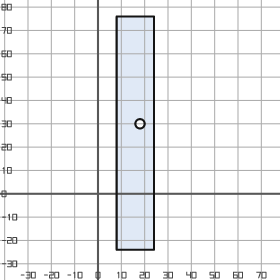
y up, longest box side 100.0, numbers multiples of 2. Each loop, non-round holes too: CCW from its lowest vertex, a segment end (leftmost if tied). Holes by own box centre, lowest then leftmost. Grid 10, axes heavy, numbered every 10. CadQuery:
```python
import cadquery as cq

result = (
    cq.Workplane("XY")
    .moveTo(8.0, -24.0)
    .lineTo(24.0, -24.0)
    .lineTo(24.0, 76.0)
    .lineTo(8.0, 76.0)
    .close()
    .moveTo(18.0, 30.0)
    .circle(2.0)
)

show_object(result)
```